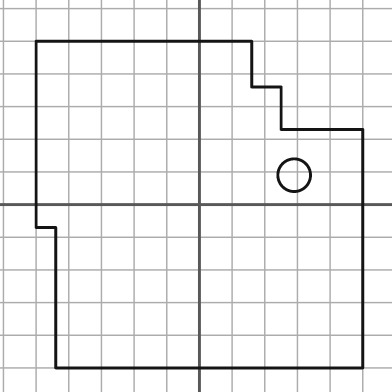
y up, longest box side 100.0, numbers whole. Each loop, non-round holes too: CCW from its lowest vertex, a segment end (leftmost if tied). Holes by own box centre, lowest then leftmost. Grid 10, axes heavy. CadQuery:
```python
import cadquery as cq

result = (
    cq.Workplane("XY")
    .moveTo(-44.0, -50.0)
    .lineTo(50.0, -50.0)
    .lineTo(50.0, 23.0)
    .lineTo(25.0, 23.0)
    .lineTo(25.0, 36.0)
    .lineTo(16.0, 36.0)
    .lineTo(16.0, 50.0)
    .lineTo(-50.0, 50.0)
    .lineTo(-50.0, -7.0)
    .lineTo(-44.0, -7.0)
    .close()
    .moveTo(29.0, 9.0)
    .circle(5.0)
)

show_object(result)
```